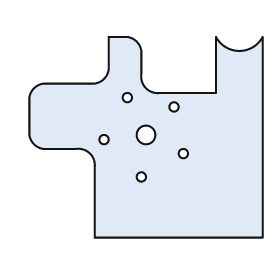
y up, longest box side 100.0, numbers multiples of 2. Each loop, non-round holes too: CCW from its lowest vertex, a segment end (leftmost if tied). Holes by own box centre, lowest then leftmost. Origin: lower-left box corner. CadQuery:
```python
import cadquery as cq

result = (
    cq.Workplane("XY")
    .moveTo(28.0, 0.0)
    .lineTo(100.0, 0.0)
    .lineTo(100.0, 86.0)
    .threePointArc((90.0, 80.0), (80.0, 86.0))
    .lineTo(80.0, 62.0)
    .lineTo(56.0, 62.0)
    .threePointArc((50.0, 64.0), (48.0, 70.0))
    .lineTo(48.0, 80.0)
    .threePointArc((46.0, 84.0), (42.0, 86.0))
    .lineTo(34.0, 86.0)
    .lineTo(34.0, 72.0)
    .threePointArc((32.0, 68.0), (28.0, 66.0))
    .lineTo(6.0, 66.0)
    .threePointArc((2.0, 64.0), (0.0, 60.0))
    .lineTo(0.0, 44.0)
    .threePointArc((2.0, 40.0), (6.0, 38.0))
    .lineTo(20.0, 38.0)
    .threePointArc((26.0, 36.0), (28.0, 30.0))
    .close()
    .moveTo(48.0, 26.0)
    .circle(2.0)
    .moveTo(66.0, 36.0)
    .circle(2.0)
    .moveTo(32.0, 42.0)
    .circle(2.0)
    .moveTo(50.0, 44.0)
    .circle(4.0)
    .moveTo(62.0, 56.0)
    .circle(2.0)
    .moveTo(42.0, 60.0)
    .circle(2.0)
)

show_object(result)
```